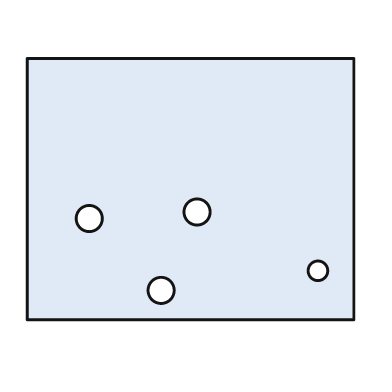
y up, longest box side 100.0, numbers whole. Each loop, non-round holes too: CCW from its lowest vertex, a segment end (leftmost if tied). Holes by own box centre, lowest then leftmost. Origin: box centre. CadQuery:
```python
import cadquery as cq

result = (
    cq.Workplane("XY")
    .moveTo(-50.0, -40.0)
    .lineTo(50.0, -40.0)
    .lineTo(50.0, 40.0)
    .lineTo(-50.0, 40.0)
    .close()
    .moveTo(-9.0, -31.0)
    .circle(4.0)
    .moveTo(39.0, -25.0)
    .circle(3.0)
    .moveTo(-31.0, -9.0)
    .circle(4.0)
    .moveTo(2.0, -7.0)
    .circle(4.0)
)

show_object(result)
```